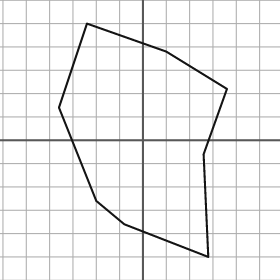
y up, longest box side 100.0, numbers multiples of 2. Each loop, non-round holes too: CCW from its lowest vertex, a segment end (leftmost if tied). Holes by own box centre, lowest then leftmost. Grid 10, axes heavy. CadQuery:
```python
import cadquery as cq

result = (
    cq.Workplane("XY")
    .moveTo(28.0, -50.0)
    .lineTo(26.0, -6.0)
    .lineTo(36.0, 22.0)
    .lineTo(10.0, 38.0)
    .lineTo(-24.0, 50.0)
    .lineTo(-36.0, 14.0)
    .lineTo(-20.0, -26.0)
    .lineTo(-8.0, -36.0)
    .close()
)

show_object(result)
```